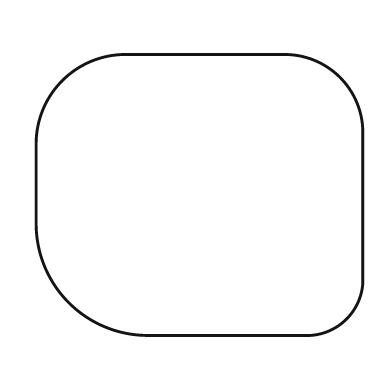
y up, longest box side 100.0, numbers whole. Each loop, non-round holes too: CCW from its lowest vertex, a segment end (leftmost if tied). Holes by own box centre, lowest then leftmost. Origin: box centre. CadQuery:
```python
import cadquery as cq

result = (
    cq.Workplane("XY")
    .moveTo(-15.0, -43.0)
    .lineTo(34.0, -43.0)
    .threePointArc((45.0, -38.0), (50.0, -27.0))
    .lineTo(50.0, 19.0)
    .threePointArc((43.0, 36.0), (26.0, 43.0))
    .lineTo(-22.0, 43.0)
    .threePointArc((-42.0, 35.0), (-50.0, 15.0))
    .lineTo(-50.0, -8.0)
    .threePointArc((-40.0, -33.0), (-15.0, -43.0))
    .close()
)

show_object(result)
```